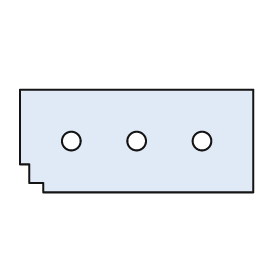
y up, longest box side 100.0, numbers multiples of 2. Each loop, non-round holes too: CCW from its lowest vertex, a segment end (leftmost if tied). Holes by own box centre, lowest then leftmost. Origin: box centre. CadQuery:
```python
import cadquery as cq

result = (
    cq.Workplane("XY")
    .moveTo(-40.0, -22.0)
    .lineTo(50.0, -22.0)
    .lineTo(50.0, 22.0)
    .lineTo(-50.0, 22.0)
    .lineTo(-50.0, -10.0)
    .lineTo(-46.0, -10.0)
    .lineTo(-46.0, -18.0)
    .lineTo(-40.0, -18.0)
    .close()
    .moveTo(-28.0, 0.0)
    .circle(4.0)
    .moveTo(0.0, 0.0)
    .circle(4.0)
    .moveTo(28.0, 0.0)
    .circle(4.0)
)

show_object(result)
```